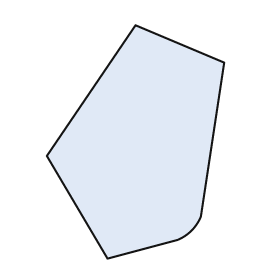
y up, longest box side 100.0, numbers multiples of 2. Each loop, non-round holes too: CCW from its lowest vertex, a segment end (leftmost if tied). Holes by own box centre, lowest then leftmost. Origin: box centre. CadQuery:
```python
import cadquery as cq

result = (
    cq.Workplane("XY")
    .moveTo(-12.0, -50.0)
    .lineTo(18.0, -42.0)
    .threePointArc((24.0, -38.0), (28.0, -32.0))
    .lineTo(38.0, 34.0)
    .lineTo(0.0, 50.0)
    .lineTo(-38.0, -6.0)
    .close()
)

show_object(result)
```